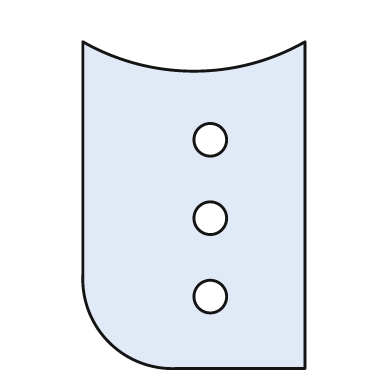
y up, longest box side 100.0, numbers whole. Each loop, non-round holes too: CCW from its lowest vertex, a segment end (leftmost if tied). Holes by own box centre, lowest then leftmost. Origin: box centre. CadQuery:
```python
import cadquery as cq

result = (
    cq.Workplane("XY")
    .moveTo(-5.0, -50.0)
    .lineTo(34.0, -50.0)
    .lineTo(34.0, 50.0)
    .threePointArc((0.0, 41.0), (-34.0, 50.0))
    .lineTo(-34.0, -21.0)
    .threePointArc((-26.0, -42.0), (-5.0, -50.0))
    .close()
    .moveTo(5.0, -28.0)
    .circle(5.0)
    .moveTo(5.0, -4.0)
    .circle(5.0)
    .moveTo(5.0, 20.0)
    .circle(5.0)
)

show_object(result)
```